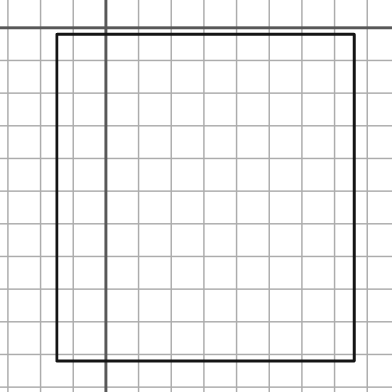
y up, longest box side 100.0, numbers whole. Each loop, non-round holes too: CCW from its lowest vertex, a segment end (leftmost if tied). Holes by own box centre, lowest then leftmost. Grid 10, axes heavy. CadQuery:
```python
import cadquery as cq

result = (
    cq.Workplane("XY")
    .moveTo(-15.0, -102.0)
    .lineTo(76.0, -102.0)
    .lineTo(76.0, -2.0)
    .lineTo(-15.0, -2.0)
    .close()
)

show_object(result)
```